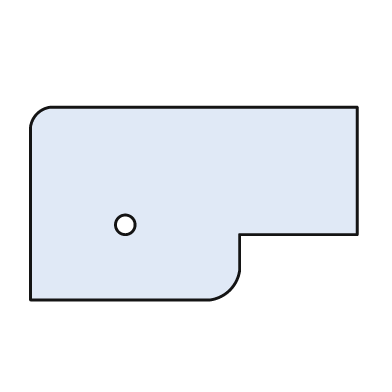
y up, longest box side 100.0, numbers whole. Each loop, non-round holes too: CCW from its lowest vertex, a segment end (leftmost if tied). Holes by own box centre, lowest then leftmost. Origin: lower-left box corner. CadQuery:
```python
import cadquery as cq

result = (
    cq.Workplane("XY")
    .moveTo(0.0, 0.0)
    .lineTo(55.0, 0.0)
    .threePointArc((61.0, 3.0), (64.0, 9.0))
    .lineTo(64.0, 20.0)
    .lineTo(100.0, 20.0)
    .lineTo(100.0, 59.0)
    .lineTo(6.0, 59.0)
    .threePointArc((2.0, 57.0), (0.0, 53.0))
    .close()
    .moveTo(29.0, 23.0)
    .circle(3.0)
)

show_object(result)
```